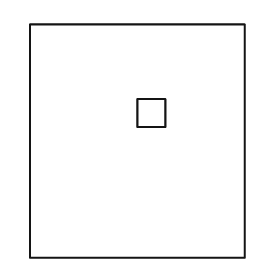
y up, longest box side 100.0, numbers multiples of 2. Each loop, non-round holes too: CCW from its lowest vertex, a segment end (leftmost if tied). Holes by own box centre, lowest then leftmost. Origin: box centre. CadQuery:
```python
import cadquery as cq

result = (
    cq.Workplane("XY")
    .moveTo(-46.0, -50.0)
    .lineTo(46.0, -50.0)
    .lineTo(46.0, 50.0)
    .lineTo(-46.0, 50.0)
    .close()
    .moveTo(0.0, 6.0)
    .lineTo(12.0, 6.0)
    .lineTo(12.0, 18.0)
    .lineTo(0.0, 18.0)
    .close()
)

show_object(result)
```